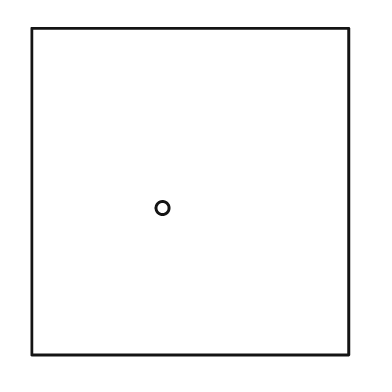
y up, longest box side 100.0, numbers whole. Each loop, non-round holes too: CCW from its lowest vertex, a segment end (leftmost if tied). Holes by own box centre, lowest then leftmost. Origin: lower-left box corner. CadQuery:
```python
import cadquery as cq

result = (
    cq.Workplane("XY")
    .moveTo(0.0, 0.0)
    .lineTo(97.0, 0.0)
    .lineTo(97.0, 100.0)
    .lineTo(0.0, 100.0)
    .close()
    .moveTo(40.0, 45.0)
    .circle(2.0)
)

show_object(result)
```